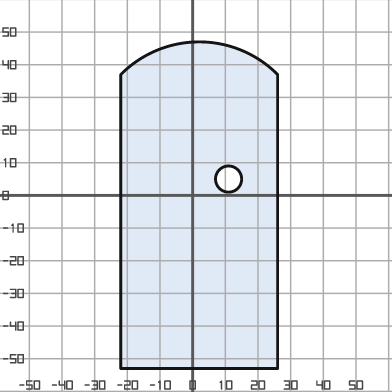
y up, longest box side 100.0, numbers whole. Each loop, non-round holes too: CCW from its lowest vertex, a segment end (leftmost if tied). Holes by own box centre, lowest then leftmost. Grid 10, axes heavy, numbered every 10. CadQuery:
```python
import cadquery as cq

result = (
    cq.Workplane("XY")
    .moveTo(-22.0, -53.0)
    .lineTo(26.0, -53.0)
    .lineTo(26.0, 37.0)
    .threePointArc((2.0, 47.0), (-22.0, 37.0))
    .close()
    .moveTo(11.0, 5.0)
    .circle(4.0)
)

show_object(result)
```